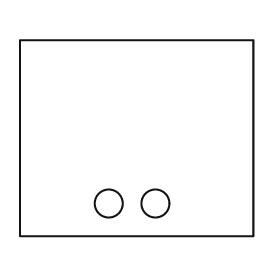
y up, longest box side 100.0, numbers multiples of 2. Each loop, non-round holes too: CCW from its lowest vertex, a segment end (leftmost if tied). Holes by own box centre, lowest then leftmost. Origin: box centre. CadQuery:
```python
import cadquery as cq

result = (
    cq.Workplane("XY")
    .moveTo(-50.0, -42.0)
    .lineTo(50.0, -42.0)
    .lineTo(50.0, 42.0)
    .lineTo(-50.0, 42.0)
    .close()
    .moveTo(-12.0, -28.0)
    .circle(6.0)
    .moveTo(8.0, -28.0)
    .circle(6.0)
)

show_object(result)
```